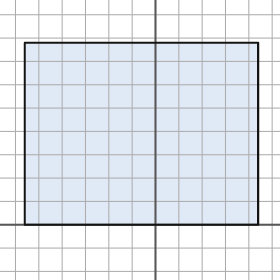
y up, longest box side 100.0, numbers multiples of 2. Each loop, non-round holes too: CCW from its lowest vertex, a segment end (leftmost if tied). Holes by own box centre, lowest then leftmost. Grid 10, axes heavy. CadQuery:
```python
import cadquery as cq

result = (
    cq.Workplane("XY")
    .moveTo(-56.0, 0.0)
    .lineTo(44.0, 0.0)
    .lineTo(44.0, 78.0)
    .lineTo(-56.0, 78.0)
    .close()
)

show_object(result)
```